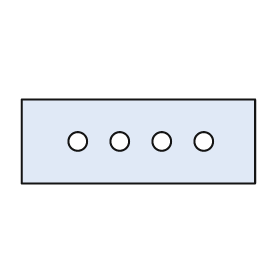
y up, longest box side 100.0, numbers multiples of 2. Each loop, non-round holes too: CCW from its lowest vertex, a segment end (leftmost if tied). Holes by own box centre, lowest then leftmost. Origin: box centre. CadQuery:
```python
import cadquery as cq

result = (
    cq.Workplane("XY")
    .moveTo(-50.0, -18.0)
    .lineTo(50.0, -18.0)
    .lineTo(50.0, 18.0)
    .lineTo(-50.0, 18.0)
    .close()
    .moveTo(-26.0, 0.0)
    .circle(4.0)
    .moveTo(-8.0, 0.0)
    .circle(4.0)
    .moveTo(10.0, 0.0)
    .circle(4.0)
    .moveTo(28.0, 0.0)
    .circle(4.0)
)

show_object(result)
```